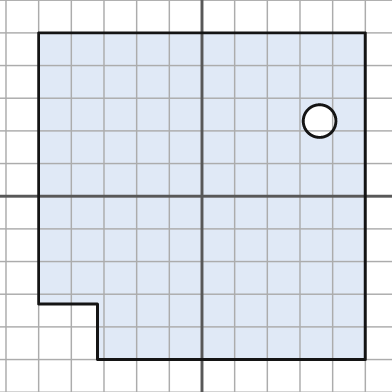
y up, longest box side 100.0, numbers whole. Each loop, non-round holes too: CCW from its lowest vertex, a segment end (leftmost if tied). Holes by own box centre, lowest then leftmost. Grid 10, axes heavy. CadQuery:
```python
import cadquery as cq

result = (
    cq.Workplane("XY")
    .moveTo(-32.0, -50.0)
    .lineTo(50.0, -50.0)
    .lineTo(50.0, 50.0)
    .lineTo(-50.0, 50.0)
    .lineTo(-50.0, -33.0)
    .lineTo(-32.0, -33.0)
    .close()
    .moveTo(36.0, 23.0)
    .circle(5.0)
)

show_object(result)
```